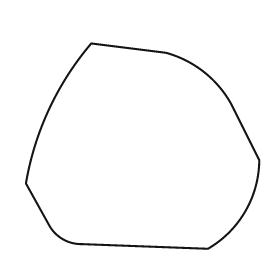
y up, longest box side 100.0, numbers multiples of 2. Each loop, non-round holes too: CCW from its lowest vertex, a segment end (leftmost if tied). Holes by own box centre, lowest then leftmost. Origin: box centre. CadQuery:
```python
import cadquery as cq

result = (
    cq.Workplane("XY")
    .moveTo(28.0, -44.0)
    .threePointArc((44.0, -28.0), (50.0, -6.0))
    .lineTo(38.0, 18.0)
    .threePointArc((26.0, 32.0), (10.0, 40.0))
    .lineTo(-22.0, 44.0)
    .threePointArc((-40.0, 16.0), (-50.0, -16.0))
    .lineTo(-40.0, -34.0)
    .threePointArc((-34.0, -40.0), (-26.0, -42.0))
    .close()
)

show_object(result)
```